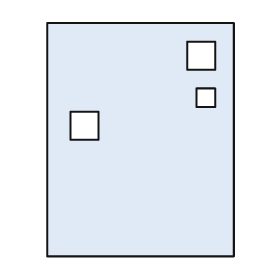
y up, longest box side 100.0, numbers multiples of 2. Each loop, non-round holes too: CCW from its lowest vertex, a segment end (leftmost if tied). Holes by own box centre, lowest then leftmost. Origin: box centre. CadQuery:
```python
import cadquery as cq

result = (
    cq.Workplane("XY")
    .moveTo(-40.0, -50.0)
    .lineTo(40.0, -50.0)
    .lineTo(40.0, 50.0)
    .lineTo(-40.0, 50.0)
    .close()
    .moveTo(-30.0, 0.0)
    .lineTo(-18.0, 0.0)
    .lineTo(-18.0, 12.0)
    .lineTo(-30.0, 12.0)
    .close()
    .moveTo(24.0, 14.0)
    .lineTo(32.0, 14.0)
    .lineTo(32.0, 22.0)
    .lineTo(24.0, 22.0)
    .close()
    .moveTo(20.0, 30.0)
    .lineTo(32.0, 30.0)
    .lineTo(32.0, 42.0)
    .lineTo(20.0, 42.0)
    .close()
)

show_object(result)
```